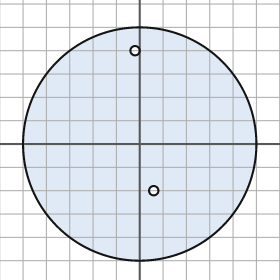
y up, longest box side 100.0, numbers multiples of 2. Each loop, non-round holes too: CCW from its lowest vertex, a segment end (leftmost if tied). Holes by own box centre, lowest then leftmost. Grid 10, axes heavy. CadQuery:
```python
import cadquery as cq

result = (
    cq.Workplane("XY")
    .moveTo(0.0, 0.0)
    .circle(50.0)
    .moveTo(6.0, -20.0)
    .circle(2.0)
    .moveTo(-2.0, 40.0)
    .circle(2.0)
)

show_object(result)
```